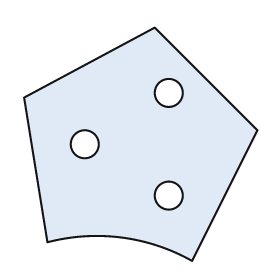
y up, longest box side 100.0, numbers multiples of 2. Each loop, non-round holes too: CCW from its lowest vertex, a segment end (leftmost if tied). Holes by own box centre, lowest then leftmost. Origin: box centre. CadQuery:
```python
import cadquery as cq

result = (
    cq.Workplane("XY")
    .moveTo(22.0, -50.0)
    .lineTo(50.0, 6.0)
    .lineTo(6.0, 50.0)
    .lineTo(-50.0, 20.0)
    .lineTo(-40.0, -42.0)
    .threePointArc((-8.0, -40.0), (22.0, -50.0))
    .close()
    .moveTo(12.0, -22.0)
    .circle(6.0)
    .moveTo(-24.0, 0.0)
    .circle(6.0)
    .moveTo(12.0, 22.0)
    .circle(6.0)
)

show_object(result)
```